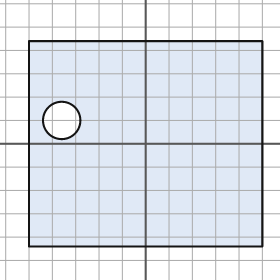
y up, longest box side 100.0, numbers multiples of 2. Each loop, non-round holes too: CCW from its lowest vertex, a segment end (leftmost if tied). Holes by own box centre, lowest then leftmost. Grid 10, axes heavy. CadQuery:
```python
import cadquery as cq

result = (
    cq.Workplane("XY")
    .moveTo(-50.0, -44.0)
    .lineTo(50.0, -44.0)
    .lineTo(50.0, 44.0)
    .lineTo(-50.0, 44.0)
    .close()
    .moveTo(-36.0, 10.0)
    .circle(8.0)
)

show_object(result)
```